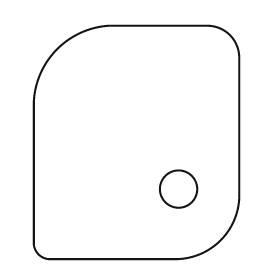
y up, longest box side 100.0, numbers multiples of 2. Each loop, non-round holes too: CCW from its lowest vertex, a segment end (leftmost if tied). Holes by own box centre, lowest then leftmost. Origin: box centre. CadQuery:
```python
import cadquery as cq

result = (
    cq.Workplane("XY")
    .moveTo(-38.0, -50.0)
    .lineTo(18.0, -50.0)
    .threePointArc((36.0, -42.0), (44.0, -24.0))
    .lineTo(44.0, 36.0)
    .threePointArc((40.0, 46.0), (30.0, 50.0))
    .lineTo(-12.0, 50.0)
    .threePointArc((-34.0, 40.0), (-44.0, 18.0))
    .lineTo(-44.0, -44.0)
    .threePointArc((-42.0, -48.0), (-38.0, -50.0))
    .close()
    .moveTo(18.0, -20.0)
    .circle(8.0)
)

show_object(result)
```